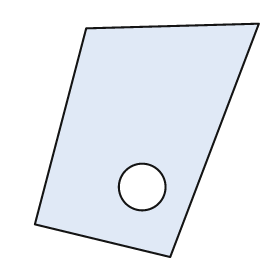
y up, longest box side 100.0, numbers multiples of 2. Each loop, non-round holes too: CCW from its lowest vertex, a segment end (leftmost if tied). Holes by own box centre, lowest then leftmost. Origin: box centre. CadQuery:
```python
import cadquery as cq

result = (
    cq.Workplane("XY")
    .moveTo(10.0, -50.0)
    .lineTo(48.0, 50.0)
    .lineTo(-26.0, 48.0)
    .lineTo(-48.0, -36.0)
    .close()
    .moveTo(-2.0, -20.0)
    .circle(10.0)
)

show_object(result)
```